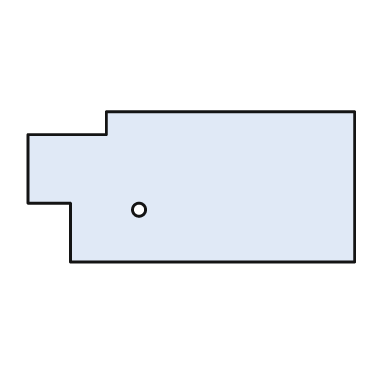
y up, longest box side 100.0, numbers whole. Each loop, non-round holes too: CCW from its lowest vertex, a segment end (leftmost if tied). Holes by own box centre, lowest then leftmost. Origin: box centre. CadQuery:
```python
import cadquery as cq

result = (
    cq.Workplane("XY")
    .moveTo(-37.0, -23.0)
    .lineTo(50.0, -23.0)
    .lineTo(50.0, 23.0)
    .lineTo(-26.0, 23.0)
    .lineTo(-26.0, 16.0)
    .lineTo(-50.0, 16.0)
    .lineTo(-50.0, -5.0)
    .lineTo(-37.0, -5.0)
    .close()
    .moveTo(-16.0, -7.0)
    .circle(2.0)
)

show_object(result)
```